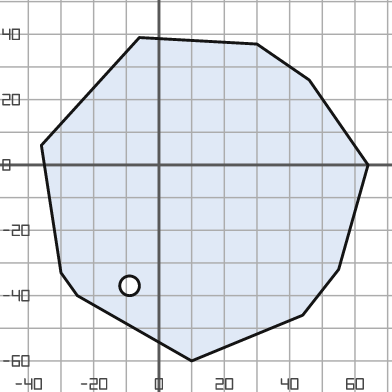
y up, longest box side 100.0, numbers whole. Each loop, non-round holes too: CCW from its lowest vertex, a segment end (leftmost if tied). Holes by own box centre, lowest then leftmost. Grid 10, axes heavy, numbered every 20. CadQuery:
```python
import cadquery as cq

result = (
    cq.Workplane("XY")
    .moveTo(10.0, -60.0)
    .lineTo(44.0, -46.0)
    .lineTo(55.0, -32.0)
    .lineTo(64.0, 0.0)
    .lineTo(46.0, 26.0)
    .lineTo(30.0, 37.0)
    .lineTo(-6.0, 39.0)
    .lineTo(-36.0, 6.0)
    .lineTo(-30.0, -33.0)
    .lineTo(-25.0, -40.0)
    .close()
    .moveTo(-9.0, -37.0)
    .circle(3.0)
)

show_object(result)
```